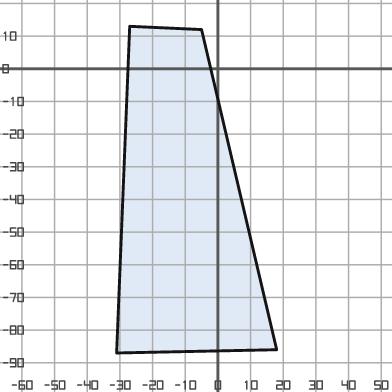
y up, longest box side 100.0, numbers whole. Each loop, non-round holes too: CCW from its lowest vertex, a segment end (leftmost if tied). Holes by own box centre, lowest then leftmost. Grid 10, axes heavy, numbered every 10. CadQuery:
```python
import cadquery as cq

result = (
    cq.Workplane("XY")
    .moveTo(-31.0, -87.0)
    .lineTo(18.0, -86.0)
    .lineTo(-5.0, 12.0)
    .lineTo(-27.0, 13.0)
    .close()
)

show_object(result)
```